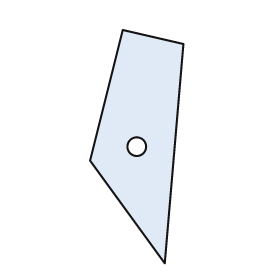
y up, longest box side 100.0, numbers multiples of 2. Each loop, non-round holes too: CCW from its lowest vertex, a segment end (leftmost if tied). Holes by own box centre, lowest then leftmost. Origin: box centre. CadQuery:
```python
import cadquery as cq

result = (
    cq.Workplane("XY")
    .moveTo(12.0, -50.0)
    .lineTo(20.0, 44.0)
    .lineTo(-6.0, 50.0)
    .lineTo(-20.0, -6.0)
    .close()
    .moveTo(0.0, 0.0)
    .circle(4.0)
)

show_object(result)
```